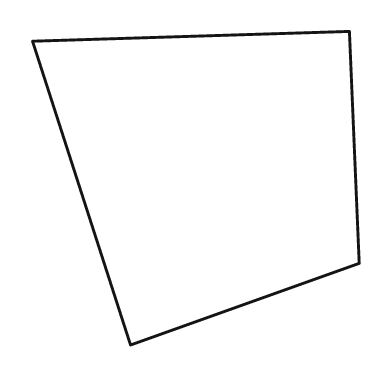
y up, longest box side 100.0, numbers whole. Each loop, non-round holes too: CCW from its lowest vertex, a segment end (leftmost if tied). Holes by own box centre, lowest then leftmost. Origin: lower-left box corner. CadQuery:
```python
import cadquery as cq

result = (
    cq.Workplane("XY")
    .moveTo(30.0, 0.0)
    .lineTo(100.0, 25.0)
    .lineTo(97.0, 96.0)
    .lineTo(0.0, 93.0)
    .close()
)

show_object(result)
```